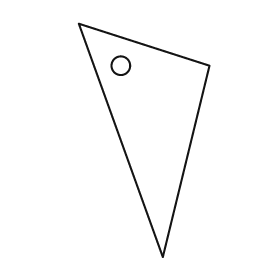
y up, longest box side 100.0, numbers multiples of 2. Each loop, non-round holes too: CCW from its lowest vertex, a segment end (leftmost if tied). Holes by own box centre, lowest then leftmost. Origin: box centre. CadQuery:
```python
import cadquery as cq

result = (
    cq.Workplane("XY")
    .moveTo(8.0, -50.0)
    .lineTo(28.0, 32.0)
    .lineTo(-28.0, 50.0)
    .close()
    .moveTo(-10.0, 32.0)
    .circle(4.0)
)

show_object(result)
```